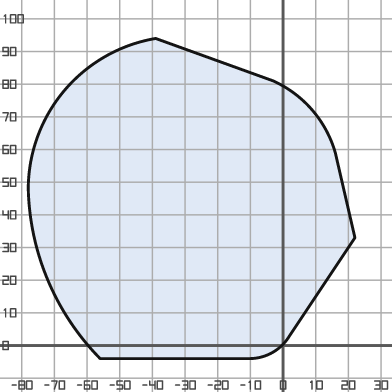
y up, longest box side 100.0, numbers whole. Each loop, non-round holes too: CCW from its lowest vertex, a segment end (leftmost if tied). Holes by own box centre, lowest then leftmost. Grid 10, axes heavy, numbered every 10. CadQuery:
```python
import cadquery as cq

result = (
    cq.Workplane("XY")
    .moveTo(-56.0, -4.0)
    .lineTo(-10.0, -4.0)
    .threePointArc((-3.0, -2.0), (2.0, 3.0))
    .lineTo(22.0, 33.0)
    .lineTo(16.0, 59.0)
    .threePointArc((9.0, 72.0), (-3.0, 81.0))
    .lineTo(-39.0, 94.0)
    .threePointArc((-67.0, 78.0), (-78.0, 48.0))
    .threePointArc((-72.0, 20.0), (-56.0, -4.0))
    .close()
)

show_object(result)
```